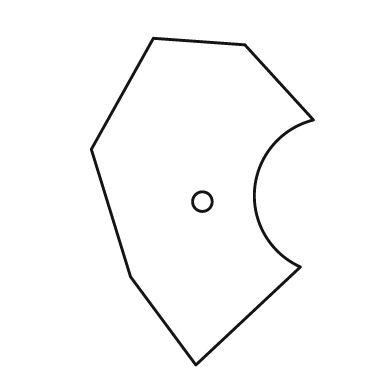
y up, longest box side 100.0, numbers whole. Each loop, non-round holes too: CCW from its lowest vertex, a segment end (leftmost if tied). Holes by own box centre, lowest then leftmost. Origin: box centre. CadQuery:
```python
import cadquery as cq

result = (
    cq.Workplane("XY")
    .moveTo(-2.0, -50.0)
    .lineTo(30.0, -20.0)
    .threePointArc((16.0, 4.0), (34.0, 25.0))
    .lineTo(13.0, 48.0)
    .lineTo(-15.0, 50.0)
    .lineTo(-34.0, 16.0)
    .lineTo(-22.0, -23.0)
    .close()
    .moveTo(0.0, 0.0)
    .circle(3.0)
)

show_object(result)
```